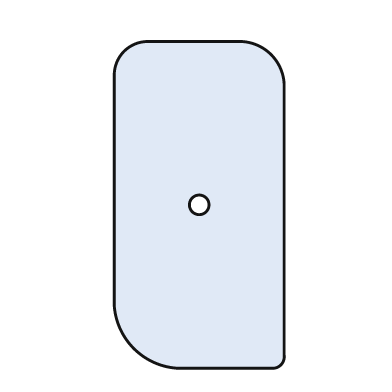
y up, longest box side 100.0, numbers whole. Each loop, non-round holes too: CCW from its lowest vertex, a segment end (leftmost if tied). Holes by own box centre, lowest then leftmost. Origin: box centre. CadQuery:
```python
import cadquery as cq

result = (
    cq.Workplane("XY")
    .moveTo(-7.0, -50.0)
    .lineTo(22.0, -50.0)
    .threePointArc((25.0, -49.0), (26.0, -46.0))
    .lineTo(26.0, 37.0)
    .threePointArc((22.0, 46.0), (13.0, 50.0))
    .lineTo(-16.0, 50.0)
    .threePointArc((-23.0, 47.0), (-26.0, 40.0))
    .lineTo(-26.0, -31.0)
    .threePointArc((-20.0, -44.0), (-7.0, -50.0))
    .close()
    .moveTo(0.0, 0.0)
    .circle(3.0)
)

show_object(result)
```